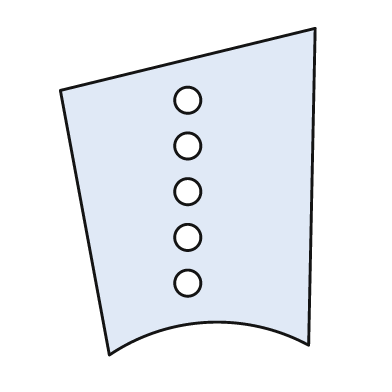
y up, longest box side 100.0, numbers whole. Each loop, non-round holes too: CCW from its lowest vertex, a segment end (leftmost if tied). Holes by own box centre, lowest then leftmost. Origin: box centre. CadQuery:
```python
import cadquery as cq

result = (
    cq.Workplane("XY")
    .moveTo(-24.0, -50.0)
    .threePointArc((6.0, -40.0), (37.0, -47.0))
    .lineTo(39.0, 50.0)
    .lineTo(-39.0, 31.0)
    .close()
    .moveTo(0.0, -28.0)
    .circle(4.0)
    .moveTo(0.0, -14.0)
    .circle(4.0)
    .moveTo(0.0, 0.0)
    .circle(4.0)
    .moveTo(0.0, 14.0)
    .circle(4.0)
    .moveTo(0.0, 28.0)
    .circle(4.0)
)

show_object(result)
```